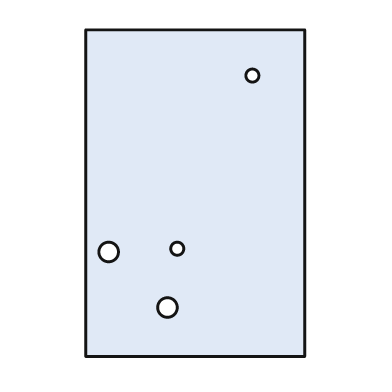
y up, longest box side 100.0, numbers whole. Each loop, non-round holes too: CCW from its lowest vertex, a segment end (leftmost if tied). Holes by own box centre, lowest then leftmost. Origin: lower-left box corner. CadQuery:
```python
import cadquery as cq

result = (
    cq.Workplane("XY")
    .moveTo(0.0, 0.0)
    .lineTo(67.0, 0.0)
    .lineTo(67.0, 100.0)
    .lineTo(0.0, 100.0)
    .close()
    .moveTo(25.0, 15.0)
    .circle(3.0)
    .moveTo(7.0, 32.0)
    .circle(3.0)
    .moveTo(28.0, 33.0)
    .circle(2.0)
    .moveTo(51.0, 86.0)
    .circle(2.0)
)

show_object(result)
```